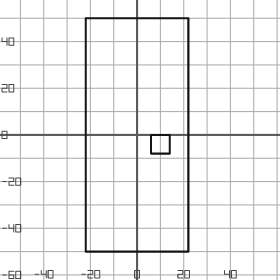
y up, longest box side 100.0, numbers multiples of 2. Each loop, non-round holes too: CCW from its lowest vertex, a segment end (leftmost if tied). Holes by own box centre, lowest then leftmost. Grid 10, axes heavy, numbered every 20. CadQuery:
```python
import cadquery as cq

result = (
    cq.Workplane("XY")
    .moveTo(-22.0, -50.0)
    .lineTo(22.0, -50.0)
    .lineTo(22.0, 50.0)
    .lineTo(-22.0, 50.0)
    .close()
    .moveTo(6.0, -8.0)
    .lineTo(14.0, -8.0)
    .lineTo(14.0, 0.0)
    .lineTo(6.0, 0.0)
    .close()
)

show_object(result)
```